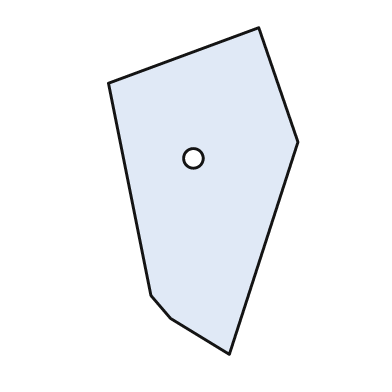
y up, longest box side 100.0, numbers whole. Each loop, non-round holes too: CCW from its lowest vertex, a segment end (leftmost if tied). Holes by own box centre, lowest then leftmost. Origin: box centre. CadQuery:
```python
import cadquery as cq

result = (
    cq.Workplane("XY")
    .moveTo(8.0, -50.0)
    .lineTo(29.0, 15.0)
    .lineTo(17.0, 50.0)
    .lineTo(-29.0, 33.0)
    .lineTo(-16.0, -32.0)
    .lineTo(-10.0, -39.0)
    .close()
    .moveTo(-3.0, 10.0)
    .circle(3.0)
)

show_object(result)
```